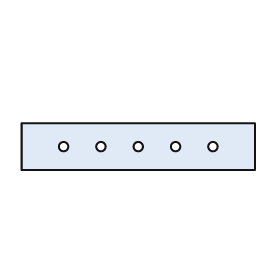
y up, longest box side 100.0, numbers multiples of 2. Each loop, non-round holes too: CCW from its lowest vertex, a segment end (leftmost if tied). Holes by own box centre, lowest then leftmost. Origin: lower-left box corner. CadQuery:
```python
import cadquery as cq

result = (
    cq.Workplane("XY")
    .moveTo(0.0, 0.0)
    .lineTo(100.0, 0.0)
    .lineTo(100.0, 20.0)
    .lineTo(0.0, 20.0)
    .close()
    .moveTo(18.0, 10.0)
    .circle(2.0)
    .moveTo(34.0, 10.0)
    .circle(2.0)
    .moveTo(50.0, 10.0)
    .circle(2.0)
    .moveTo(66.0, 10.0)
    .circle(2.0)
    .moveTo(82.0, 10.0)
    .circle(2.0)
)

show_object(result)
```